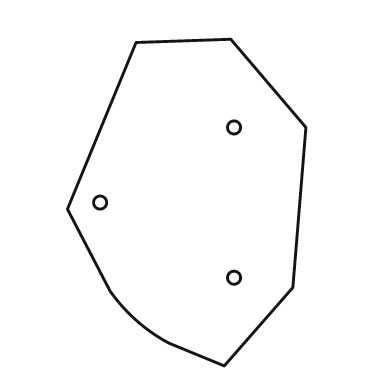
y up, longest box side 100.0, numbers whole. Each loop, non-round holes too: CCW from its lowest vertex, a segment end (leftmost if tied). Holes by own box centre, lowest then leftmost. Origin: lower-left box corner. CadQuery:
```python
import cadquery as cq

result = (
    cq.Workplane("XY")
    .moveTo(48.0, 0.0)
    .lineTo(69.0, 24.0)
    .lineTo(73.0, 73.0)
    .lineTo(50.0, 100.0)
    .lineTo(21.0, 99.0)
    .lineTo(0.0, 48.0)
    .lineTo(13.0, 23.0)
    .threePointArc((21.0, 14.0), (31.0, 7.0))
    .close()
    .moveTo(51.0, 27.0)
    .circle(2.0)
    .moveTo(10.0, 50.0)
    .circle(2.0)
    .moveTo(51.0, 73.0)
    .circle(2.0)
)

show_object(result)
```